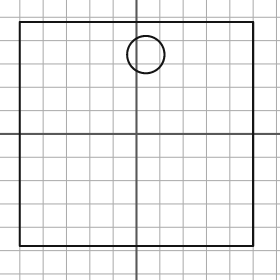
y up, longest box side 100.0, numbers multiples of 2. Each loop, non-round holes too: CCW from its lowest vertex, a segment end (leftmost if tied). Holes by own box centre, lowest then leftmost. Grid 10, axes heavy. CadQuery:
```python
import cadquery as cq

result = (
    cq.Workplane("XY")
    .moveTo(-50.0, -48.0)
    .lineTo(50.0, -48.0)
    .lineTo(50.0, 48.0)
    .lineTo(-50.0, 48.0)
    .close()
    .moveTo(4.0, 34.0)
    .circle(8.0)
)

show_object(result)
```